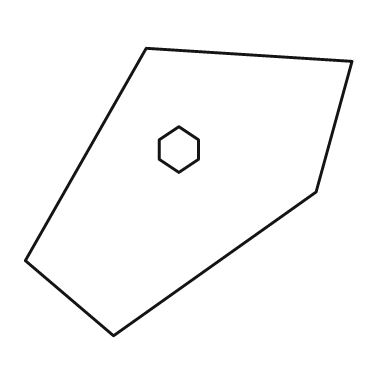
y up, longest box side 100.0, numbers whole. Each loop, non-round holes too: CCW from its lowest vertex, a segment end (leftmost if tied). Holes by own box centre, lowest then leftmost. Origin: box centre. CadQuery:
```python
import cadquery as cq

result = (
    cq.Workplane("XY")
    .moveTo(-23.0, -44.0)
    .lineTo(39.0, 0.0)
    .lineTo(50.0, 40.0)
    .lineTo(-13.0, 44.0)
    .lineTo(-50.0, -21.0)
    .close()
    .moveTo(-3.0, 6.0)
    .lineTo(3.0, 10.0)
    .lineTo(3.0, 16.0)
    .lineTo(-3.0, 20.0)
    .lineTo(-9.0, 16.0)
    .lineTo(-9.0, 10.0)
    .close()
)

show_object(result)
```